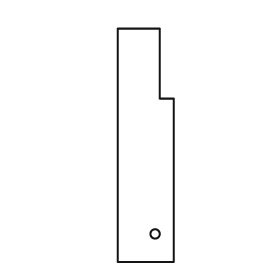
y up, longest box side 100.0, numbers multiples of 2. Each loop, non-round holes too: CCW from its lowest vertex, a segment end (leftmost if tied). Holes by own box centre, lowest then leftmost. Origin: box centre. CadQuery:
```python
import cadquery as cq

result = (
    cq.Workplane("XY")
    .moveTo(-12.0, -50.0)
    .lineTo(12.0, -50.0)
    .lineTo(12.0, 20.0)
    .lineTo(6.0, 20.0)
    .lineTo(6.0, 50.0)
    .lineTo(-12.0, 50.0)
    .close()
    .moveTo(4.0, -38.0)
    .circle(2.0)
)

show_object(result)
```